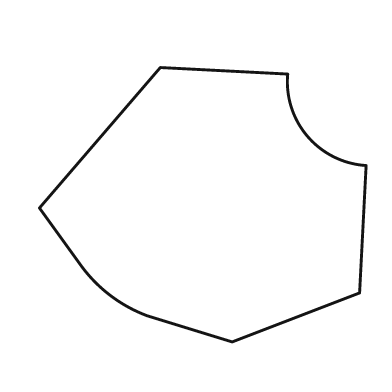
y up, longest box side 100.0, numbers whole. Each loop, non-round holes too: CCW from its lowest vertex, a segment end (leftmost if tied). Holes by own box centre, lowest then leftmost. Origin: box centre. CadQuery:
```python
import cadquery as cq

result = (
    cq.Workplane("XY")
    .moveTo(9.0, -42.0)
    .lineTo(48.0, -27.0)
    .lineTo(50.0, 12.0)
    .threePointArc((32.0, 21.0), (26.0, 40.0))
    .lineTo(-13.0, 42.0)
    .lineTo(-50.0, -1.0)
    .lineTo(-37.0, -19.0)
    .threePointArc((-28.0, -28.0), (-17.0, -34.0))
    .close()
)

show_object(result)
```